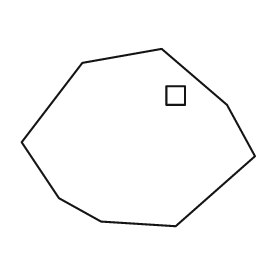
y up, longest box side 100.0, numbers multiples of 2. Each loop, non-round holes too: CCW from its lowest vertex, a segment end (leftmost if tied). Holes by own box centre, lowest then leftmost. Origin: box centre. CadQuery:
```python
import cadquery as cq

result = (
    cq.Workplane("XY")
    .moveTo(16.0, -38.0)
    .lineTo(50.0, -8.0)
    .lineTo(38.0, 14.0)
    .lineTo(10.0, 38.0)
    .lineTo(-24.0, 32.0)
    .lineTo(-50.0, -2.0)
    .lineTo(-34.0, -26.0)
    .lineTo(-16.0, -36.0)
    .close()
    .moveTo(12.0, 14.0)
    .lineTo(20.0, 14.0)
    .lineTo(20.0, 22.0)
    .lineTo(12.0, 22.0)
    .close()
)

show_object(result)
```